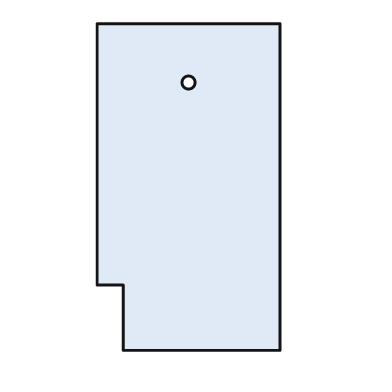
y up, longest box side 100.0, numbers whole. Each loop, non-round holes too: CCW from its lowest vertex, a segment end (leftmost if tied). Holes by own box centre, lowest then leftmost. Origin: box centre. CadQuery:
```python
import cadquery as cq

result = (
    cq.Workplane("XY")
    .moveTo(-20.0, -50.0)
    .lineTo(28.0, -50.0)
    .lineTo(28.0, 50.0)
    .lineTo(-28.0, 50.0)
    .lineTo(-28.0, -30.0)
    .lineTo(-20.0, -30.0)
    .close()
    .moveTo(0.0, 32.0)
    .circle(2.0)
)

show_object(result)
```